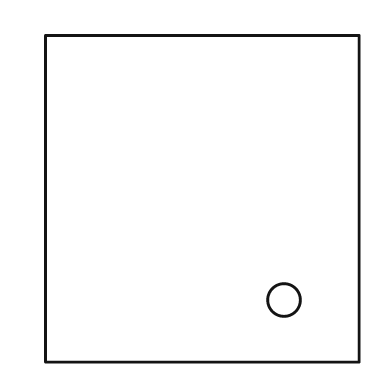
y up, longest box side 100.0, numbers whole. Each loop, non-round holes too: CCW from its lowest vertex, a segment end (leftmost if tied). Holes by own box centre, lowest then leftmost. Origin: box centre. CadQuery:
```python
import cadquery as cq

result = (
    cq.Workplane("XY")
    .moveTo(-48.0, -50.0)
    .lineTo(48.0, -50.0)
    .lineTo(48.0, 50.0)
    .lineTo(-48.0, 50.0)
    .close()
    .moveTo(25.0, -31.0)
    .circle(5.0)
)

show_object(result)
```